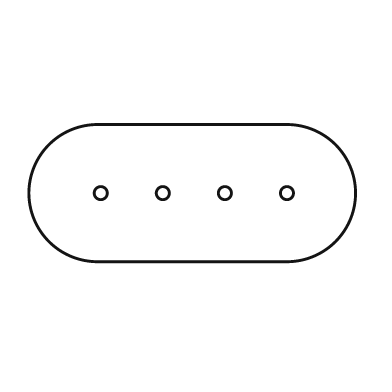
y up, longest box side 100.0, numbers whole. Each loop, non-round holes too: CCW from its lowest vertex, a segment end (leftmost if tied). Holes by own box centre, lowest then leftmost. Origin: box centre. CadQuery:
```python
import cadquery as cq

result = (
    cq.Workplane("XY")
    .moveTo(-29.0, -21.0)
    .lineTo(29.0, -21.0)
    .threePointArc((50.0, 0.0), (29.0, 21.0))
    .lineTo(-29.0, 21.0)
    .threePointArc((-50.0, 0.0), (-29.0, -21.0))
    .close()
    .moveTo(-28.0, 0.0)
    .circle(2.0)
    .moveTo(-9.0, 0.0)
    .circle(2.0)
    .moveTo(10.0, 0.0)
    .circle(2.0)
    .moveTo(29.0, 0.0)
    .circle(2.0)
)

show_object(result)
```